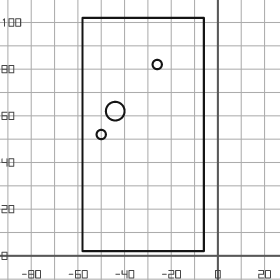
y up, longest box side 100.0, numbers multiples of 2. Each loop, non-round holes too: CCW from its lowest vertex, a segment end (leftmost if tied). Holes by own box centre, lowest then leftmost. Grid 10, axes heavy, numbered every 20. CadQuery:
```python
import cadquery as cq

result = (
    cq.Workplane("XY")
    .moveTo(-58.0, 2.0)
    .lineTo(-6.0, 2.0)
    .lineTo(-6.0, 102.0)
    .lineTo(-58.0, 102.0)
    .close()
    .moveTo(-50.0, 52.0)
    .circle(2.0)
    .moveTo(-44.0, 62.0)
    .circle(4.0)
    .moveTo(-26.0, 82.0)
    .circle(2.0)
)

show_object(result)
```